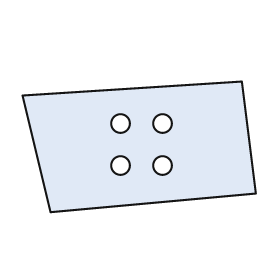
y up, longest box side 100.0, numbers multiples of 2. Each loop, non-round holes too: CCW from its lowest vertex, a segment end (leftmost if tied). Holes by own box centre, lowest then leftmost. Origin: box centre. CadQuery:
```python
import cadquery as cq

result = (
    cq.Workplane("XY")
    .moveTo(-38.0, -28.0)
    .lineTo(50.0, -20.0)
    .lineTo(44.0, 28.0)
    .lineTo(-50.0, 22.0)
    .close()
    .moveTo(-8.0, -8.0)
    .circle(4.0)
    .moveTo(10.0, -8.0)
    .circle(4.0)
    .moveTo(-8.0, 10.0)
    .circle(4.0)
    .moveTo(10.0, 10.0)
    .circle(4.0)
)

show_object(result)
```